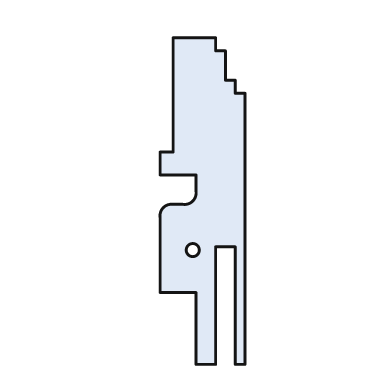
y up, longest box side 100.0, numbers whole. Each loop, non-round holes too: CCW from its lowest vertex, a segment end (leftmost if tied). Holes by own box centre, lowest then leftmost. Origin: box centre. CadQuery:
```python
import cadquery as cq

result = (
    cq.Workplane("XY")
    .moveTo(-2.0, -50.0)
    .lineTo(4.0, -50.0)
    .lineTo(4.0, -14.0)
    .lineTo(10.0, -14.0)
    .lineTo(10.0, -50.0)
    .lineTo(13.0, -50.0)
    .lineTo(13.0, 33.0)
    .lineTo(10.0, 33.0)
    .lineTo(10.0, 37.0)
    .lineTo(7.0, 37.0)
    .lineTo(7.0, 46.0)
    .lineTo(4.0, 46.0)
    .lineTo(4.0, 50.0)
    .lineTo(-9.0, 50.0)
    .lineTo(-9.0, 15.0)
    .lineTo(-13.0, 15.0)
    .lineTo(-13.0, 8.0)
    .lineTo(-2.0, 8.0)
    .lineTo(-2.0, 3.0)
    .threePointArc((-3.0, 0.0), (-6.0, -1.0))
    .lineTo(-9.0, -1.0)
    .threePointArc((-12.0, -2.0), (-13.0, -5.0))
    .lineTo(-13.0, -28.0)
    .lineTo(-2.0, -28.0)
    .close()
    .moveTo(-3.0, -15.0)
    .circle(2.0)
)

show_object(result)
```